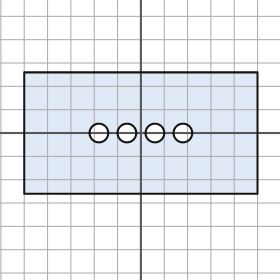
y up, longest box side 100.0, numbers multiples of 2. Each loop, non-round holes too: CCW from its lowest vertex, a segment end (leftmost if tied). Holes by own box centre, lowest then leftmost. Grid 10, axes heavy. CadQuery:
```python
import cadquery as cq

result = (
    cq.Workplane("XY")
    .moveTo(-50.0, -26.0)
    .lineTo(50.0, -26.0)
    .lineTo(50.0, 26.0)
    .lineTo(-50.0, 26.0)
    .close()
    .moveTo(-18.0, 0.0)
    .circle(4.0)
    .moveTo(-6.0, 0.0)
    .circle(4.0)
    .moveTo(6.0, 0.0)
    .circle(4.0)
    .moveTo(18.0, 0.0)
    .circle(4.0)
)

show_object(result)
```